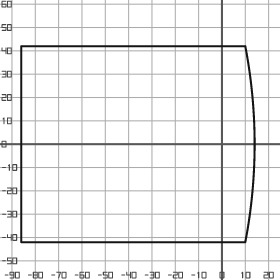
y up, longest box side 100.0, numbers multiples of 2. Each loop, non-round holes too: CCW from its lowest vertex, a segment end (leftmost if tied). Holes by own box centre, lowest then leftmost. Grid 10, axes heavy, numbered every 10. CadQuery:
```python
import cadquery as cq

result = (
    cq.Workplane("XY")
    .moveTo(-86.0, -42.0)
    .lineTo(10.0, -42.0)
    .threePointArc((14.0, 0.0), (10.0, 42.0))
    .lineTo(-86.0, 42.0)
    .close()
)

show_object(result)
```